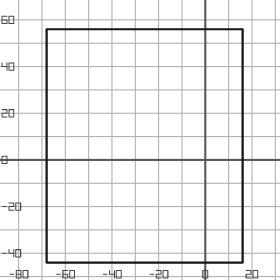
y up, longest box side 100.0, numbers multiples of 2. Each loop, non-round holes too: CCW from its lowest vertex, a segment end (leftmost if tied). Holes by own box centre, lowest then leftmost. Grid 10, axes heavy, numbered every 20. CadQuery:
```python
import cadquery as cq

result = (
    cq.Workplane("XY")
    .moveTo(-68.0, -44.0)
    .lineTo(16.0, -44.0)
    .lineTo(16.0, 56.0)
    .lineTo(-68.0, 56.0)
    .close()
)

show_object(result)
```